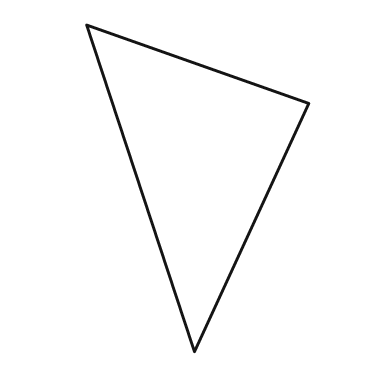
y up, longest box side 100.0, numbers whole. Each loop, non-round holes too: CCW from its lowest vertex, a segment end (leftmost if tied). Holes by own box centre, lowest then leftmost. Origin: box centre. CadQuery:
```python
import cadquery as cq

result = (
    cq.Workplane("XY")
    .moveTo(-1.0, -50.0)
    .lineTo(34.0, 26.0)
    .lineTo(-34.0, 50.0)
    .close()
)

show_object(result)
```